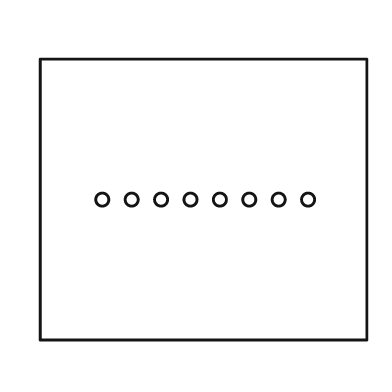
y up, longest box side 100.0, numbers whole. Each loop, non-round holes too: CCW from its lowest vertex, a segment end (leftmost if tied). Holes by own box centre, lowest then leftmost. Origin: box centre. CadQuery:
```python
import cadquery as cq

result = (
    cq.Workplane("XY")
    .moveTo(-50.0, -43.0)
    .lineTo(50.0, -43.0)
    .lineTo(50.0, 43.0)
    .lineTo(-50.0, 43.0)
    .close()
    .moveTo(-31.0, 0.0)
    .circle(2.0)
    .moveTo(-22.0, 0.0)
    .circle(2.0)
    .moveTo(-13.0, 0.0)
    .circle(2.0)
    .moveTo(-4.0, 0.0)
    .circle(2.0)
    .moveTo(5.0, 0.0)
    .circle(2.0)
    .moveTo(14.0, 0.0)
    .circle(2.0)
    .moveTo(23.0, 0.0)
    .circle(2.0)
    .moveTo(32.0, 0.0)
    .circle(2.0)
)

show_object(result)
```